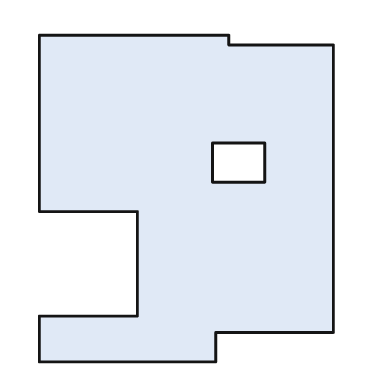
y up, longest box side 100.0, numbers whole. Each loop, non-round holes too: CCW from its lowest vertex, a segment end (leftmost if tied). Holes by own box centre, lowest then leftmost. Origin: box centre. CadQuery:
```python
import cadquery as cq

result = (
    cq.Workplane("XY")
    .moveTo(-45.0, -50.0)
    .lineTo(9.0, -50.0)
    .lineTo(9.0, -41.0)
    .lineTo(45.0, -41.0)
    .lineTo(45.0, 47.0)
    .lineTo(13.0, 47.0)
    .lineTo(13.0, 50.0)
    .lineTo(-45.0, 50.0)
    .lineTo(-45.0, -4.0)
    .lineTo(-15.0, -4.0)
    .lineTo(-15.0, -36.0)
    .lineTo(-45.0, -36.0)
    .close()
    .moveTo(8.0, 5.0)
    .lineTo(24.0, 5.0)
    .lineTo(24.0, 17.0)
    .lineTo(8.0, 17.0)
    .close()
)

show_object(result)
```